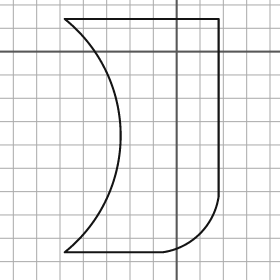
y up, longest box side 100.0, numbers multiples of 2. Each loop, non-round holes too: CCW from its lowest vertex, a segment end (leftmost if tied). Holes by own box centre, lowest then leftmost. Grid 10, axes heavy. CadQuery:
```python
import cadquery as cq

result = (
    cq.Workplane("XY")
    .moveTo(-48.0, -86.0)
    .lineTo(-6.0, -86.0)
    .threePointArc((10.0, -78.0), (18.0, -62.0))
    .lineTo(18.0, 14.0)
    .lineTo(-48.0, 14.0)
    .threePointArc((-24.0, -36.0), (-48.0, -86.0))
    .close()
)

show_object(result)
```